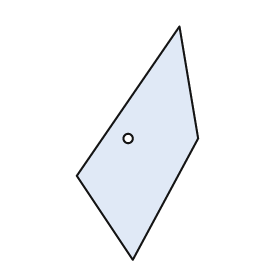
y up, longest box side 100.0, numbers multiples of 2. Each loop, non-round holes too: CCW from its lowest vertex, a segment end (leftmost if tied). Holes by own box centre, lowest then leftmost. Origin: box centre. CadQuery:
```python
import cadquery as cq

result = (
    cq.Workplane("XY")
    .moveTo(-2.0, -50.0)
    .lineTo(26.0, 2.0)
    .lineTo(18.0, 50.0)
    .lineTo(-26.0, -14.0)
    .close()
    .moveTo(-4.0, 2.0)
    .circle(2.0)
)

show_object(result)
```